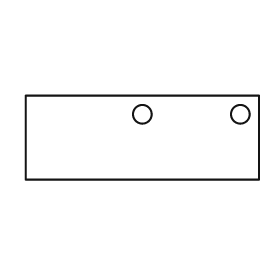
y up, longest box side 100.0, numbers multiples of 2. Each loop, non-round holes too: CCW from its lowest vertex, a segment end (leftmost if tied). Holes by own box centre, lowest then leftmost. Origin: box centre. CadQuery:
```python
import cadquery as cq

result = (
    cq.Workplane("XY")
    .moveTo(-50.0, -18.0)
    .lineTo(50.0, -18.0)
    .lineTo(50.0, 18.0)
    .lineTo(-50.0, 18.0)
    .close()
    .moveTo(0.0, 10.0)
    .circle(4.0)
    .moveTo(42.0, 10.0)
    .circle(4.0)
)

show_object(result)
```